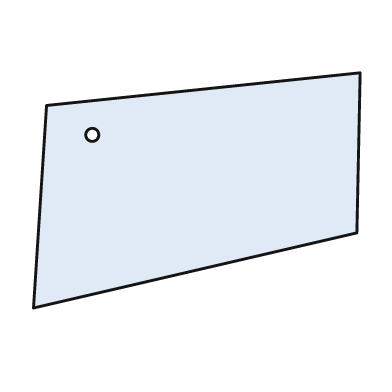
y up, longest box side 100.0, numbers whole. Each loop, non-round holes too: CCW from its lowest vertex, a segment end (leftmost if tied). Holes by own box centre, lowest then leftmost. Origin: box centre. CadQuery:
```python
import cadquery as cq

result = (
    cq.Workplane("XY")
    .moveTo(-50.0, -36.0)
    .lineTo(49.0, -13.0)
    .lineTo(50.0, 36.0)
    .lineTo(-46.0, 26.0)
    .close()
    .moveTo(-32.0, 17.0)
    .circle(2.0)
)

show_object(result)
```